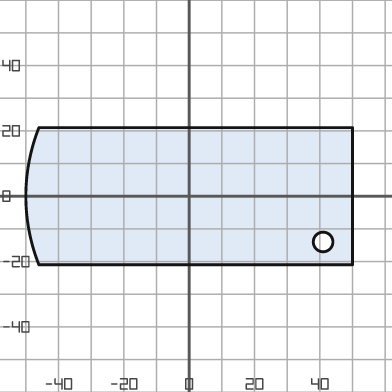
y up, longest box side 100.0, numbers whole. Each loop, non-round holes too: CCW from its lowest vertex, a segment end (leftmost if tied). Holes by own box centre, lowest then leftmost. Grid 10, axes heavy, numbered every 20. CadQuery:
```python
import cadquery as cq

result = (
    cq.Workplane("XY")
    .moveTo(-46.0, -21.0)
    .lineTo(50.0, -21.0)
    .lineTo(50.0, 21.0)
    .lineTo(-46.0, 21.0)
    .threePointArc((-50.0, 0.0), (-46.0, -21.0))
    .close()
    .moveTo(41.0, -14.0)
    .circle(3.0)
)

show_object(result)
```